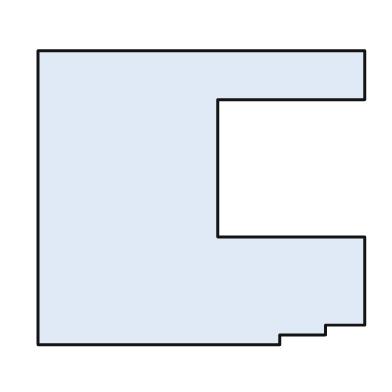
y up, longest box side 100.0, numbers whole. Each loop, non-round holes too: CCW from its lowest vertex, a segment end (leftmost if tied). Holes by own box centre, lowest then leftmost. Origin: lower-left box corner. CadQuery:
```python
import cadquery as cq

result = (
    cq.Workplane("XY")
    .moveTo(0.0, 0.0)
    .lineTo(74.0, 0.0)
    .lineTo(74.0, 3.0)
    .lineTo(88.0, 3.0)
    .lineTo(88.0, 6.0)
    .lineTo(100.0, 6.0)
    .lineTo(100.0, 33.0)
    .lineTo(55.0, 33.0)
    .lineTo(55.0, 75.0)
    .lineTo(100.0, 75.0)
    .lineTo(100.0, 90.0)
    .lineTo(0.0, 90.0)
    .close()
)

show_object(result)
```